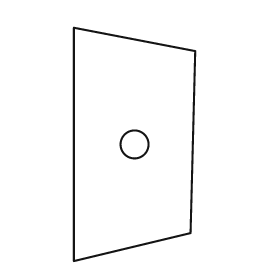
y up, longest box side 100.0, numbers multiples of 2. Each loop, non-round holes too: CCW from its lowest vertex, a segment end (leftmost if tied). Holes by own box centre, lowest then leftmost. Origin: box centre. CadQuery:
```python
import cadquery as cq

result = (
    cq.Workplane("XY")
    .moveTo(-26.0, -50.0)
    .lineTo(24.0, -38.0)
    .lineTo(26.0, 40.0)
    .lineTo(-26.0, 50.0)
    .close()
    .moveTo(0.0, 0.0)
    .circle(6.0)
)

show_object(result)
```